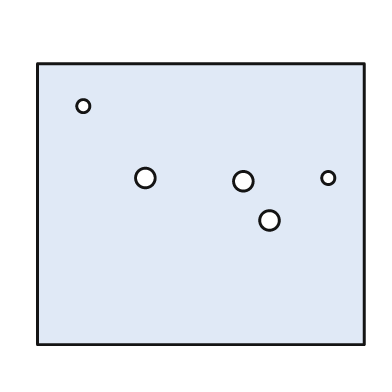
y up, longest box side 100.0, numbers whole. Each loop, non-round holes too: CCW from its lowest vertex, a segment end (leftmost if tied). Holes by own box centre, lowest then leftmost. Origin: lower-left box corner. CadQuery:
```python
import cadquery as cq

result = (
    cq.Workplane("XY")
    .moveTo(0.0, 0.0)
    .lineTo(100.0, 0.0)
    .lineTo(100.0, 86.0)
    .lineTo(0.0, 86.0)
    .close()
    .moveTo(71.0, 38.0)
    .circle(3.0)
    .moveTo(63.0, 50.0)
    .circle(3.0)
    .moveTo(33.0, 51.0)
    .circle(3.0)
    .moveTo(89.0, 51.0)
    .circle(2.0)
    .moveTo(14.0, 73.0)
    .circle(2.0)
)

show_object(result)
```